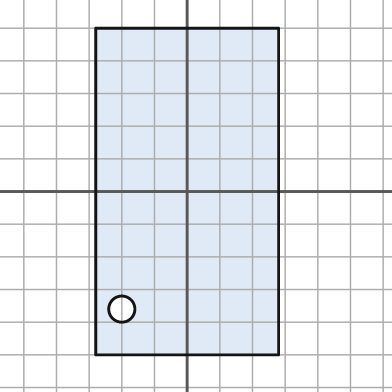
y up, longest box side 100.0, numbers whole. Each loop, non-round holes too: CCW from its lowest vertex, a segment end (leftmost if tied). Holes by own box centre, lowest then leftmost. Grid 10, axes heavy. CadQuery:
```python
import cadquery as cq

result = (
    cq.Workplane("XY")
    .moveTo(-28.0, -50.0)
    .lineTo(28.0, -50.0)
    .lineTo(28.0, 50.0)
    .lineTo(-28.0, 50.0)
    .close()
    .moveTo(-20.0, -36.0)
    .circle(4.0)
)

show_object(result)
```